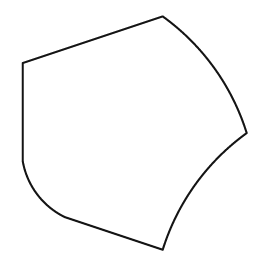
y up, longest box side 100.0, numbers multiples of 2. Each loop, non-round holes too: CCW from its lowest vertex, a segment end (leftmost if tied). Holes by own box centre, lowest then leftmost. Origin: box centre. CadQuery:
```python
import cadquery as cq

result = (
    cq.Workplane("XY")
    .moveTo(12.0, -50.0)
    .threePointArc((26.0, -22.0), (48.0, 0.0))
    .threePointArc((34.0, 28.0), (12.0, 50.0))
    .lineTo(-48.0, 30.0)
    .lineTo(-48.0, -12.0)
    .threePointArc((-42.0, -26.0), (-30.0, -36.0))
    .close()
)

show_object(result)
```